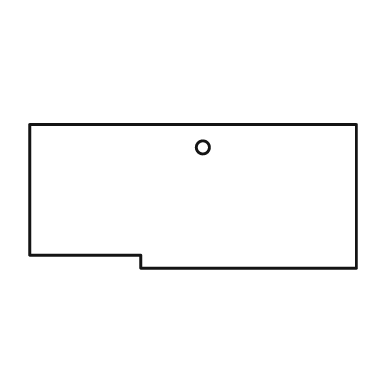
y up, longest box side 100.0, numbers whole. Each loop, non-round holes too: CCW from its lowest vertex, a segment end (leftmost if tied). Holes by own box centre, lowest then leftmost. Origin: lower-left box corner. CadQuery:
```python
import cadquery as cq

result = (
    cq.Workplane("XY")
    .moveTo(34.0, 0.0)
    .lineTo(100.0, 0.0)
    .lineTo(100.0, 44.0)
    .lineTo(0.0, 44.0)
    .lineTo(0.0, 4.0)
    .lineTo(34.0, 4.0)
    .close()
    .moveTo(53.0, 37.0)
    .circle(2.0)
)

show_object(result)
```